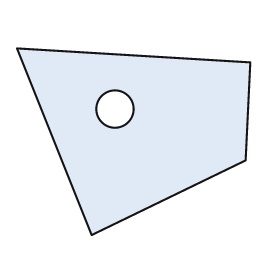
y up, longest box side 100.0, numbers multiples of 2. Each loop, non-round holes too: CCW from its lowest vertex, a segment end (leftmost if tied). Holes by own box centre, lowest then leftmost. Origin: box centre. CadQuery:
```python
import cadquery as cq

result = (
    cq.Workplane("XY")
    .moveTo(-18.0, -40.0)
    .lineTo(48.0, -8.0)
    .lineTo(50.0, 34.0)
    .lineTo(-50.0, 40.0)
    .close()
    .moveTo(-8.0, 14.0)
    .circle(8.0)
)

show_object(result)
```